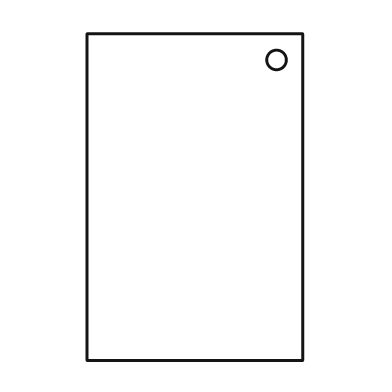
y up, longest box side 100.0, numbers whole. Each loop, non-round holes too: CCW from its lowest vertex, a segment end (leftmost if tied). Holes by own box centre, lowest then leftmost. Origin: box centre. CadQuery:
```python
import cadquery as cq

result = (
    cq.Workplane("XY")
    .moveTo(-33.0, -50.0)
    .lineTo(33.0, -50.0)
    .lineTo(33.0, 50.0)
    .lineTo(-33.0, 50.0)
    .close()
    .moveTo(25.0, 42.0)
    .circle(3.0)
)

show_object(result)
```